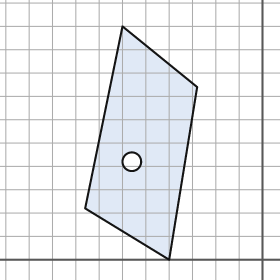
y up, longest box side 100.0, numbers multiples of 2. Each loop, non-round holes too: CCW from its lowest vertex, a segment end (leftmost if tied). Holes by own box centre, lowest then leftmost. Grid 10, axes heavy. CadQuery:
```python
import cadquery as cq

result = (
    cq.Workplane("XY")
    .moveTo(-40.0, 0.0)
    .lineTo(-28.0, 74.0)
    .lineTo(-60.0, 100.0)
    .lineTo(-76.0, 22.0)
    .close()
    .moveTo(-56.0, 42.0)
    .circle(4.0)
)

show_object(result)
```